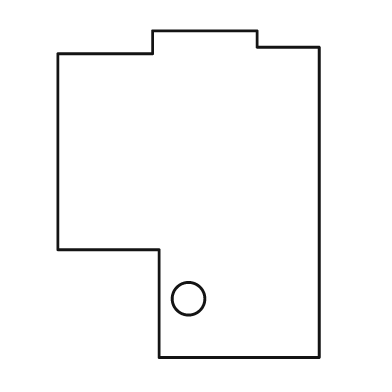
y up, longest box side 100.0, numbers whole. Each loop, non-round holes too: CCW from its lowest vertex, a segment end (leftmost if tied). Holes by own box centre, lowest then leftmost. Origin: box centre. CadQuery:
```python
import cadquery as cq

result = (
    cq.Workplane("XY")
    .moveTo(-9.0, -50.0)
    .lineTo(40.0, -50.0)
    .lineTo(40.0, 45.0)
    .lineTo(21.0, 45.0)
    .lineTo(21.0, 50.0)
    .lineTo(-11.0, 50.0)
    .lineTo(-11.0, 43.0)
    .lineTo(-40.0, 43.0)
    .lineTo(-40.0, -17.0)
    .lineTo(-9.0, -17.0)
    .close()
    .moveTo(0.0, -32.0)
    .circle(5.0)
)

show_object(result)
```